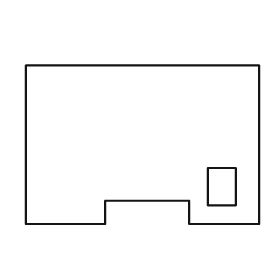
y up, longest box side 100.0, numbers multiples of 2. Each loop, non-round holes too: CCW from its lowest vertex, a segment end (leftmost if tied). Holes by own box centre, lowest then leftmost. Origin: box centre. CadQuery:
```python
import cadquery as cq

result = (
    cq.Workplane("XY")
    .moveTo(-50.0, -34.0)
    .lineTo(-16.0, -34.0)
    .lineTo(-16.0, -24.0)
    .lineTo(20.0, -24.0)
    .lineTo(20.0, -34.0)
    .lineTo(50.0, -34.0)
    .lineTo(50.0, 34.0)
    .lineTo(-50.0, 34.0)
    .close()
    .moveTo(28.0, -26.0)
    .lineTo(40.0, -26.0)
    .lineTo(40.0, -10.0)
    .lineTo(28.0, -10.0)
    .close()
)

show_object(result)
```